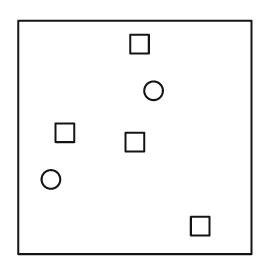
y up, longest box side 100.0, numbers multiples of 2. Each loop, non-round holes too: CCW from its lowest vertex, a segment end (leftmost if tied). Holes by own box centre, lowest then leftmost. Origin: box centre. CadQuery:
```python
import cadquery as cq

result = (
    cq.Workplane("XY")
    .moveTo(-50.0, -50.0)
    .lineTo(50.0, -50.0)
    .lineTo(50.0, 50.0)
    .lineTo(-50.0, 50.0)
    .close()
    .moveTo(24.0, -42.0)
    .lineTo(32.0, -42.0)
    .lineTo(32.0, -34.0)
    .lineTo(24.0, -34.0)
    .close()
    .moveTo(-36.0, -18.0)
    .circle(4.0)
    .moveTo(-4.0, -6.0)
    .lineTo(4.0, -6.0)
    .lineTo(4.0, 2.0)
    .lineTo(-4.0, 2.0)
    .close()
    .moveTo(-34.0, -2.0)
    .lineTo(-26.0, -2.0)
    .lineTo(-26.0, 6.0)
    .lineTo(-34.0, 6.0)
    .close()
    .moveTo(8.0, 20.0)
    .circle(4.0)
    .moveTo(-2.0, 36.0)
    .lineTo(6.0, 36.0)
    .lineTo(6.0, 44.0)
    .lineTo(-2.0, 44.0)
    .close()
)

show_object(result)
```